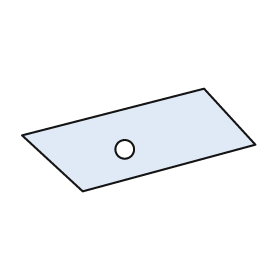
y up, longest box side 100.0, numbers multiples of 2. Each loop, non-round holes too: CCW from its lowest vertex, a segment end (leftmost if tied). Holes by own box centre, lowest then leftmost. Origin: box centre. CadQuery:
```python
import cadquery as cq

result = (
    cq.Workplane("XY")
    .moveTo(-24.0, -22.0)
    .lineTo(50.0, -2.0)
    .lineTo(28.0, 22.0)
    .lineTo(-50.0, 2.0)
    .close()
    .moveTo(-6.0, -4.0)
    .circle(4.0)
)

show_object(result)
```